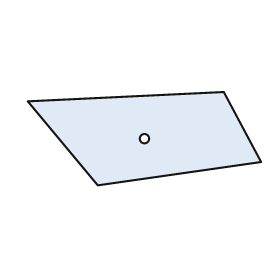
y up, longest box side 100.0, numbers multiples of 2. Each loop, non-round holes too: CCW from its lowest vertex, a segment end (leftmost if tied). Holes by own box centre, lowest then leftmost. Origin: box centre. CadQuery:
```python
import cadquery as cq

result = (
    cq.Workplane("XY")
    .moveTo(-20.0, -20.0)
    .lineTo(50.0, -10.0)
    .lineTo(34.0, 20.0)
    .lineTo(-50.0, 16.0)
    .close()
    .moveTo(0.0, 0.0)
    .circle(2.0)
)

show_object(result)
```